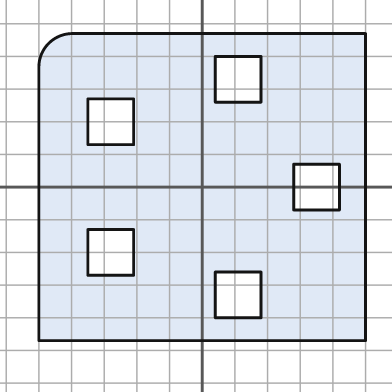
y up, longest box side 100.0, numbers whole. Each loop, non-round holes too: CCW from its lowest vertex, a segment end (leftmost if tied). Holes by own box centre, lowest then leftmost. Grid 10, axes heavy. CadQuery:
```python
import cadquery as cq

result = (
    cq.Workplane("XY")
    .moveTo(-50.0, -47.0)
    .lineTo(50.0, -47.0)
    .lineTo(50.0, 47.0)
    .lineTo(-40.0, 47.0)
    .threePointArc((-47.0, 44.0), (-50.0, 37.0))
    .close()
    .moveTo(4.0, -40.0)
    .lineTo(18.0, -40.0)
    .lineTo(18.0, -26.0)
    .lineTo(4.0, -26.0)
    .close()
    .moveTo(-35.0, -27.0)
    .lineTo(-21.0, -27.0)
    .lineTo(-21.0, -13.0)
    .lineTo(-35.0, -13.0)
    .close()
    .moveTo(28.0, -7.0)
    .lineTo(42.0, -7.0)
    .lineTo(42.0, 7.0)
    .lineTo(28.0, 7.0)
    .close()
    .moveTo(-35.0, 13.0)
    .lineTo(-21.0, 13.0)
    .lineTo(-21.0, 27.0)
    .lineTo(-35.0, 27.0)
    .close()
    .moveTo(4.0, 26.0)
    .lineTo(18.0, 26.0)
    .lineTo(18.0, 40.0)
    .lineTo(4.0, 40.0)
    .close()
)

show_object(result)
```